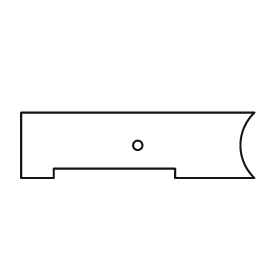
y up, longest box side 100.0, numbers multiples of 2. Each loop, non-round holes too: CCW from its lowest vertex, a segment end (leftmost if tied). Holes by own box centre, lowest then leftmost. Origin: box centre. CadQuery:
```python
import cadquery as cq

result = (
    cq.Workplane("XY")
    .moveTo(-50.0, -14.0)
    .lineTo(-36.0, -14.0)
    .lineTo(-36.0, -10.0)
    .lineTo(16.0, -10.0)
    .lineTo(16.0, -14.0)
    .lineTo(50.0, -14.0)
    .threePointArc((44.0, 0.0), (50.0, 14.0))
    .lineTo(-50.0, 14.0)
    .close()
    .moveTo(0.0, 0.0)
    .circle(2.0)
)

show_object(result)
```